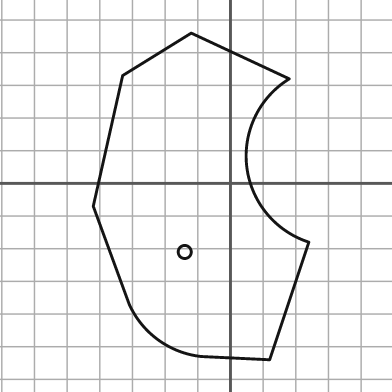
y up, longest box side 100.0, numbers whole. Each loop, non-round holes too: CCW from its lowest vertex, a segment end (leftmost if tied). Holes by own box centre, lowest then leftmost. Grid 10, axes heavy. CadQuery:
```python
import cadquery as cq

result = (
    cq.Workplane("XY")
    .moveTo(12.0, -54.0)
    .lineTo(24.0, -18.0)
    .threePointArc((5.0, 5.0), (18.0, 32.0))
    .lineTo(-12.0, 46.0)
    .lineTo(-33.0, 33.0)
    .lineTo(-42.0, -7.0)
    .lineTo(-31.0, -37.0)
    .threePointArc((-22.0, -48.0), (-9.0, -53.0))
    .close()
    .moveTo(-14.0, -21.0)
    .circle(2.0)
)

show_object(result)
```